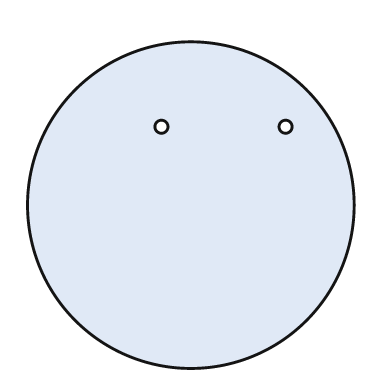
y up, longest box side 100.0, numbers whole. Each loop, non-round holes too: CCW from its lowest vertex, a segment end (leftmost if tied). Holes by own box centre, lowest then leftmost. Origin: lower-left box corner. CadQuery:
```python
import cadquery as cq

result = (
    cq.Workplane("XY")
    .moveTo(50.0, 50.0)
    .circle(50.0)
    .moveTo(41.0, 74.0)
    .circle(2.0)
    .moveTo(79.0, 74.0)
    .circle(2.0)
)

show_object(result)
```